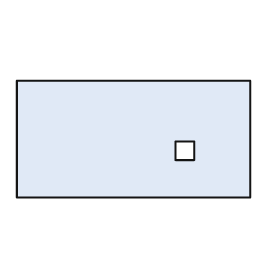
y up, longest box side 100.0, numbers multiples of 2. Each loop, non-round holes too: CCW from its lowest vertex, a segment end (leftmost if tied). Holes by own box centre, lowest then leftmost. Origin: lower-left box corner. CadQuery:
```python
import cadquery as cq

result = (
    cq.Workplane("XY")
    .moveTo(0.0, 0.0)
    .lineTo(100.0, 0.0)
    .lineTo(100.0, 50.0)
    .lineTo(0.0, 50.0)
    .close()
    .moveTo(68.0, 16.0)
    .lineTo(76.0, 16.0)
    .lineTo(76.0, 24.0)
    .lineTo(68.0, 24.0)
    .close()
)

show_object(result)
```